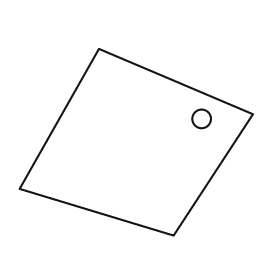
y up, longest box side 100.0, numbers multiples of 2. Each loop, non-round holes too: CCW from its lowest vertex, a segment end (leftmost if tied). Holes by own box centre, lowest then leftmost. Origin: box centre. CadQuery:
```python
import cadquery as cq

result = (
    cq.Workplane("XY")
    .moveTo(16.0, -40.0)
    .lineTo(50.0, 12.0)
    .lineTo(-16.0, 40.0)
    .lineTo(-50.0, -20.0)
    .close()
    .moveTo(28.0, 10.0)
    .circle(4.0)
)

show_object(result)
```